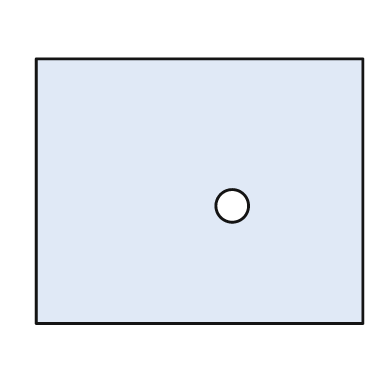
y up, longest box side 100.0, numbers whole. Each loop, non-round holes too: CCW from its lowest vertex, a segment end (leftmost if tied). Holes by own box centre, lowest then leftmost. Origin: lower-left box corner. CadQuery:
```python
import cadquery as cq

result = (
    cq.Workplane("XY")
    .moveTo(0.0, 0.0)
    .lineTo(100.0, 0.0)
    .lineTo(100.0, 81.0)
    .lineTo(0.0, 81.0)
    .close()
    .moveTo(60.0, 36.0)
    .circle(5.0)
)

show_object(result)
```